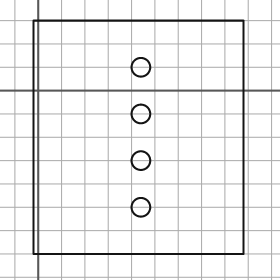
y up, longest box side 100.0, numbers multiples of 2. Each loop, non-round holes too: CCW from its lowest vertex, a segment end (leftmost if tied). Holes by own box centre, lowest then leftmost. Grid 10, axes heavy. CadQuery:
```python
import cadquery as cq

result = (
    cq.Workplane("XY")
    .moveTo(-2.0, -70.0)
    .lineTo(88.0, -70.0)
    .lineTo(88.0, 30.0)
    .lineTo(-2.0, 30.0)
    .close()
    .moveTo(44.0, -50.0)
    .circle(4.0)
    .moveTo(44.0, -30.0)
    .circle(4.0)
    .moveTo(44.0, -10.0)
    .circle(4.0)
    .moveTo(44.0, 10.0)
    .circle(4.0)
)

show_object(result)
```